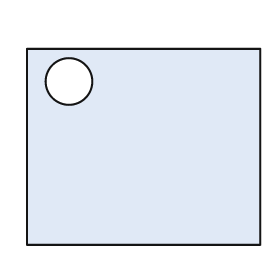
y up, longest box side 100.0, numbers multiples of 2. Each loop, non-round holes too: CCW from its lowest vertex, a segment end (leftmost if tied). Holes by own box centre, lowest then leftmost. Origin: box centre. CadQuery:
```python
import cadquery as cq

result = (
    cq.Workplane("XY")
    .moveTo(-50.0, -42.0)
    .lineTo(50.0, -42.0)
    .lineTo(50.0, 42.0)
    .lineTo(-50.0, 42.0)
    .close()
    .moveTo(-32.0, 28.0)
    .circle(10.0)
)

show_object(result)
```